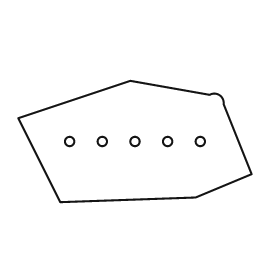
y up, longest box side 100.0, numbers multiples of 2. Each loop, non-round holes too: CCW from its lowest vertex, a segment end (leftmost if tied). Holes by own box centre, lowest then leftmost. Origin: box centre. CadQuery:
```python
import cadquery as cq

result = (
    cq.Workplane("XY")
    .moveTo(-32.0, -26.0)
    .lineTo(26.0, -24.0)
    .lineTo(50.0, -14.0)
    .lineTo(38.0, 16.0)
    .threePointArc((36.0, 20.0), (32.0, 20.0))
    .lineTo(-2.0, 26.0)
    .lineTo(-50.0, 10.0)
    .close()
    .moveTo(-28.0, 0.0)
    .circle(2.0)
    .moveTo(-14.0, 0.0)
    .circle(2.0)
    .moveTo(0.0, 0.0)
    .circle(2.0)
    .moveTo(14.0, 0.0)
    .circle(2.0)
    .moveTo(28.0, 0.0)
    .circle(2.0)
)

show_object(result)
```